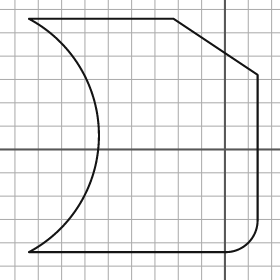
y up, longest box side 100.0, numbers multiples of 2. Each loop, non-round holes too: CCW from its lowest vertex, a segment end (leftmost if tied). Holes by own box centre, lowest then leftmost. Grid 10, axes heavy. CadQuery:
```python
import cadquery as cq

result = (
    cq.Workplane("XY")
    .moveTo(-84.0, -44.0)
    .lineTo(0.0, -44.0)
    .threePointArc((10.0, -40.0), (14.0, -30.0))
    .lineTo(14.0, 32.0)
    .lineTo(-22.0, 56.0)
    .lineTo(-84.0, 56.0)
    .threePointArc((-54.0, 6.0), (-84.0, -44.0))
    .close()
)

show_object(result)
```